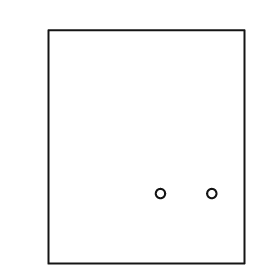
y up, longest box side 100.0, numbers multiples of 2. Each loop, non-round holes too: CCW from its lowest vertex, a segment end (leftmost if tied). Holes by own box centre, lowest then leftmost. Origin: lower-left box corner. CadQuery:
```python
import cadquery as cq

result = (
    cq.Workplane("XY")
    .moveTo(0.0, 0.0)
    .lineTo(84.0, 0.0)
    .lineTo(84.0, 100.0)
    .lineTo(0.0, 100.0)
    .close()
    .moveTo(48.0, 30.0)
    .circle(2.0)
    .moveTo(70.0, 30.0)
    .circle(2.0)
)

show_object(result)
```